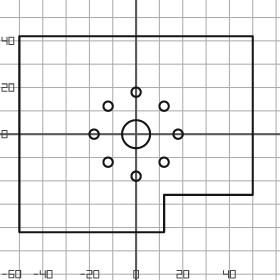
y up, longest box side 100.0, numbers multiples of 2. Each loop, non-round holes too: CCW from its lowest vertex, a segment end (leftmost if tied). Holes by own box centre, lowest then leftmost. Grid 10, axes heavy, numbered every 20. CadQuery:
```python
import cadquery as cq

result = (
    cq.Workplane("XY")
    .moveTo(-50.0, -42.0)
    .lineTo(12.0, -42.0)
    .lineTo(12.0, -26.0)
    .lineTo(50.0, -26.0)
    .lineTo(50.0, 42.0)
    .lineTo(-50.0, 42.0)
    .close()
    .moveTo(0.0, -18.0)
    .circle(2.0)
    .moveTo(-12.0, -12.0)
    .circle(2.0)
    .moveTo(12.0, -12.0)
    .circle(2.0)
    .moveTo(-18.0, 0.0)
    .circle(2.0)
    .moveTo(0.0, 0.0)
    .circle(6.0)
    .moveTo(18.0, 0.0)
    .circle(2.0)
    .moveTo(-12.0, 12.0)
    .circle(2.0)
    .moveTo(12.0, 12.0)
    .circle(2.0)
    .moveTo(0.0, 18.0)
    .circle(2.0)
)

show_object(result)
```